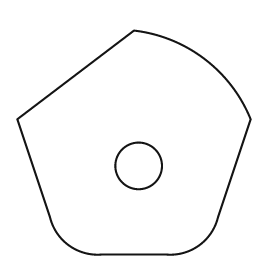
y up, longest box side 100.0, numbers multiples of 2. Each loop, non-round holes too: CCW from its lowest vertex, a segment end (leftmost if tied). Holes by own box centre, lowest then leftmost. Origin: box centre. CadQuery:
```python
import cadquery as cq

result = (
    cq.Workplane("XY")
    .moveTo(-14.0, -48.0)
    .lineTo(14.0, -48.0)
    .threePointArc((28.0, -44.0), (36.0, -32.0))
    .lineTo(50.0, 10.0)
    .threePointArc((30.0, 36.0), (0.0, 48.0))
    .lineTo(-50.0, 10.0)
    .lineTo(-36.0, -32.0)
    .threePointArc((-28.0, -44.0), (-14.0, -48.0))
    .close()
    .moveTo(2.0, -10.0)
    .circle(10.0)
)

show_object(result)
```